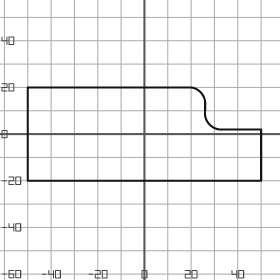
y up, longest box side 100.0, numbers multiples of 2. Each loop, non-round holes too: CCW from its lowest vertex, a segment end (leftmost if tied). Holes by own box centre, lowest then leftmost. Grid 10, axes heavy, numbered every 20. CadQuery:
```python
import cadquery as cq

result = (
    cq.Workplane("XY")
    .moveTo(-50.0, -20.0)
    .lineTo(50.0, -20.0)
    .lineTo(50.0, 2.0)
    .lineTo(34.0, 2.0)
    .threePointArc((28.0, 4.0), (26.0, 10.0))
    .lineTo(26.0, 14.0)
    .threePointArc((24.0, 18.0), (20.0, 20.0))
    .lineTo(-50.0, 20.0)
    .close()
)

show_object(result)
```